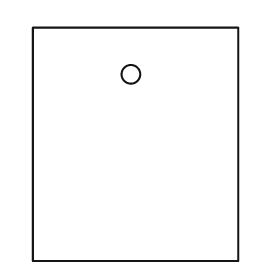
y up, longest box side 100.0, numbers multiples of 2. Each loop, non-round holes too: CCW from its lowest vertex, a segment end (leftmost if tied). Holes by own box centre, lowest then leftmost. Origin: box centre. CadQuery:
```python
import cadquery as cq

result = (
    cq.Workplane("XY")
    .moveTo(-44.0, -50.0)
    .lineTo(44.0, -50.0)
    .lineTo(44.0, 50.0)
    .lineTo(-44.0, 50.0)
    .close()
    .moveTo(-2.0, 30.0)
    .circle(4.0)
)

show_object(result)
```